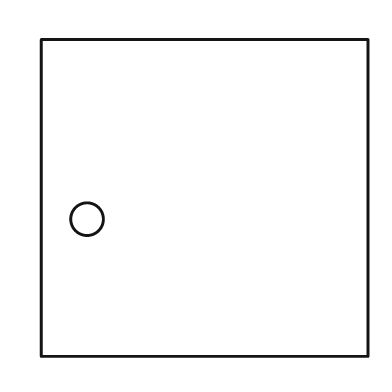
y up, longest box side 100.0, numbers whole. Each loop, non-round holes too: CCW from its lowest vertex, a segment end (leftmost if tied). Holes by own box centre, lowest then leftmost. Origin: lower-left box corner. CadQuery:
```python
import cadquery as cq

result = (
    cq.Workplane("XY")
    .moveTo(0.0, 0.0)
    .lineTo(100.0, 0.0)
    .lineTo(100.0, 97.0)
    .lineTo(0.0, 97.0)
    .close()
    .moveTo(14.0, 42.0)
    .circle(5.0)
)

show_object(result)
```